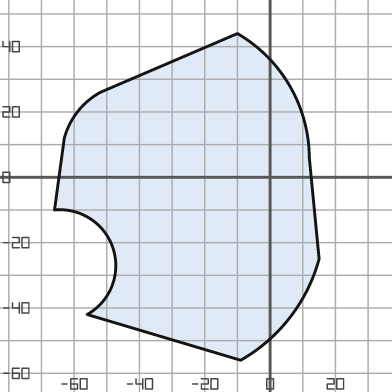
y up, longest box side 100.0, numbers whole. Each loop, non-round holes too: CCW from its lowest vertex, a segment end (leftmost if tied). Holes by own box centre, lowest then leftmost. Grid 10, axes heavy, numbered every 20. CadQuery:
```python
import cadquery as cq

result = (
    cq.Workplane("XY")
    .moveTo(-9.0, -56.0)
    .threePointArc((6.0, -43.0), (15.0, -25.0))
    .lineTo(12.0, 6.0)
    .threePointArc((6.0, 28.0), (-10.0, 44.0))
    .lineTo(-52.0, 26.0)
    .threePointArc((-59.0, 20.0), (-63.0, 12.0))
    .lineTo(-66.0, -10.0)
    .threePointArc((-48.0, -22.0), (-56.0, -42.0))
    .close()
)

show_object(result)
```